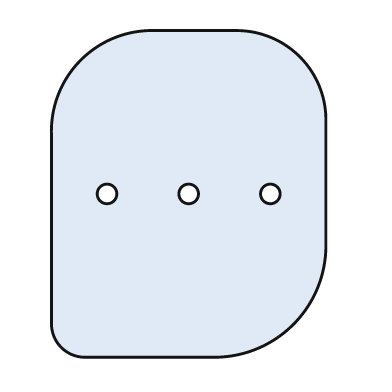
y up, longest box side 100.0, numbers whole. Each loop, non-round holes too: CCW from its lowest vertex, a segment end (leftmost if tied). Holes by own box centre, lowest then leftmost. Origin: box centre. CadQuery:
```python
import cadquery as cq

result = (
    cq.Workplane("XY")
    .moveTo(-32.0, -50.0)
    .lineTo(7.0, -50.0)
    .threePointArc((32.0, -40.0), (42.0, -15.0))
    .lineTo(42.0, 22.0)
    .threePointArc((34.0, 42.0), (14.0, 50.0))
    .lineTo(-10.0, 50.0)
    .threePointArc((-33.0, 41.0), (-42.0, 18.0))
    .lineTo(-42.0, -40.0)
    .threePointArc((-39.0, -47.0), (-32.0, -50.0))
    .close()
    .moveTo(-25.0, 0.0)
    .circle(3.0)
    .moveTo(0.0, 0.0)
    .circle(3.0)
    .moveTo(25.0, 0.0)
    .circle(3.0)
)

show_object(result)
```